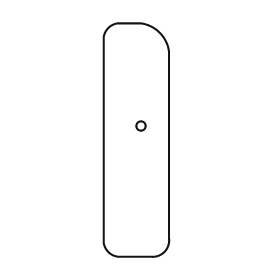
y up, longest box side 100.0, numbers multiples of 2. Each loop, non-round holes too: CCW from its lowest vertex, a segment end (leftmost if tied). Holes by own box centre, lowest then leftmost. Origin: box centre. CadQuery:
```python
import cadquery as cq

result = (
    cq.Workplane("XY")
    .moveTo(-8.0, -50.0)
    .lineTo(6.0, -50.0)
    .threePointArc((12.0, -48.0), (14.0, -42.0))
    .lineTo(14.0, 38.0)
    .threePointArc((10.0, 46.0), (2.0, 50.0))
    .lineTo(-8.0, 50.0)
    .threePointArc((-12.0, 48.0), (-14.0, 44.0))
    .lineTo(-14.0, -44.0)
    .threePointArc((-12.0, -48.0), (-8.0, -50.0))
    .close()
    .moveTo(2.0, 6.0)
    .circle(2.0)
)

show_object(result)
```